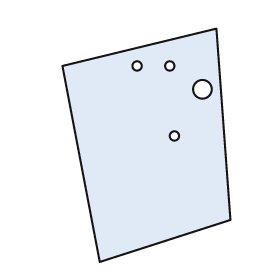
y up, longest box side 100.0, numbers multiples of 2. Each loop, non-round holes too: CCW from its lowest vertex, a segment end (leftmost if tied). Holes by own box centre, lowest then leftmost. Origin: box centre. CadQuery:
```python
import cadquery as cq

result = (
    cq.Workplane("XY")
    .moveTo(-20.0, -50.0)
    .lineTo(36.0, -32.0)
    .lineTo(30.0, 50.0)
    .lineTo(-36.0, 34.0)
    .close()
    .moveTo(12.0, 4.0)
    .circle(2.0)
    .moveTo(24.0, 24.0)
    .circle(4.0)
    .moveTo(-4.0, 34.0)
    .circle(2.0)
    .moveTo(10.0, 34.0)
    .circle(2.0)
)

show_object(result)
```